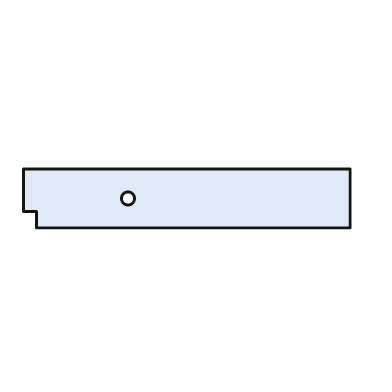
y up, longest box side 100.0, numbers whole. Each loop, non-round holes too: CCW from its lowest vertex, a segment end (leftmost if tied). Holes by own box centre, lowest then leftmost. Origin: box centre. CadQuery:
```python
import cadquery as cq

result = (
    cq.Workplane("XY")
    .moveTo(-46.0, -9.0)
    .lineTo(50.0, -9.0)
    .lineTo(50.0, 9.0)
    .lineTo(-50.0, 9.0)
    .lineTo(-50.0, -4.0)
    .lineTo(-46.0, -4.0)
    .close()
    .moveTo(-18.0, 0.0)
    .circle(2.0)
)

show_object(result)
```